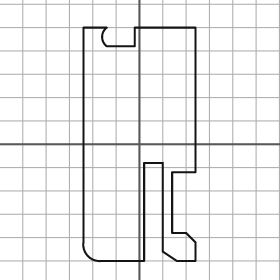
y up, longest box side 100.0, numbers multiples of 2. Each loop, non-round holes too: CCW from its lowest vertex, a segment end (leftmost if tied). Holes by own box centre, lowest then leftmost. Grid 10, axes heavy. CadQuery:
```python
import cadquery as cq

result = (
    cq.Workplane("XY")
    .moveTo(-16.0, -50.0)
    .lineTo(2.0, -50.0)
    .lineTo(2.0, -8.0)
    .lineTo(10.0, -8.0)
    .lineTo(10.0, -46.0)
    .lineTo(16.0, -50.0)
    .lineTo(24.0, -50.0)
    .lineTo(24.0, -42.0)
    .lineTo(20.0, -38.0)
    .lineTo(14.0, -38.0)
    .lineTo(14.0, -12.0)
    .lineTo(24.0, -12.0)
    .lineTo(24.0, 50.0)
    .lineTo(-2.0, 50.0)
    .lineTo(-2.0, 42.0)
    .lineTo(-14.0, 42.0)
    .threePointArc((-16.0, 46.0), (-14.0, 50.0))
    .lineTo(-24.0, 50.0)
    .lineTo(-24.0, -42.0)
    .threePointArc((-22.0, -48.0), (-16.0, -50.0))
    .close()
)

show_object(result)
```